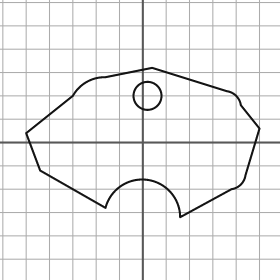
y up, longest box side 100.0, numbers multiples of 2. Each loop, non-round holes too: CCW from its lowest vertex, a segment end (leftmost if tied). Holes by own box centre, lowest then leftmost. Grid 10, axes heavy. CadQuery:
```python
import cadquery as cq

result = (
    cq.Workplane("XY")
    .moveTo(16.0, -32.0)
    .lineTo(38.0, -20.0)
    .threePointArc((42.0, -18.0), (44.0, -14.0))
    .lineTo(50.0, 6.0)
    .lineTo(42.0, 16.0)
    .threePointArc((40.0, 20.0), (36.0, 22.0))
    .lineTo(4.0, 32.0)
    .lineTo(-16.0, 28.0)
    .threePointArc((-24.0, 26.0), (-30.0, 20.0))
    .lineTo(-50.0, 4.0)
    .lineTo(-44.0, -12.0)
    .lineTo(-16.0, -28.0)
    .threePointArc((2.0, -16.0), (16.0, -32.0))
    .close()
    .moveTo(2.0, 20.0)
    .circle(6.0)
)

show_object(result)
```